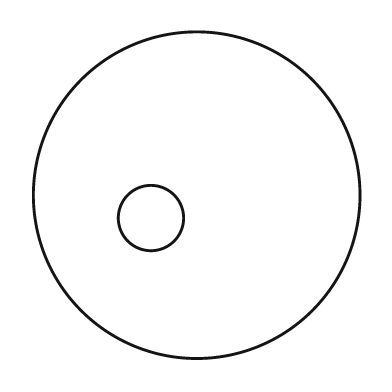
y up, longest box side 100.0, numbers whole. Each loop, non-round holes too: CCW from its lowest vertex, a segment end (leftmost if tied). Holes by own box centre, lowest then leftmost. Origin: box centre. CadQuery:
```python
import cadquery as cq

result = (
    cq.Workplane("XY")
    .moveTo(0.0, 0.0)
    .circle(50.0)
    .moveTo(-14.0, -7.0)
    .circle(10.0)
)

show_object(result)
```